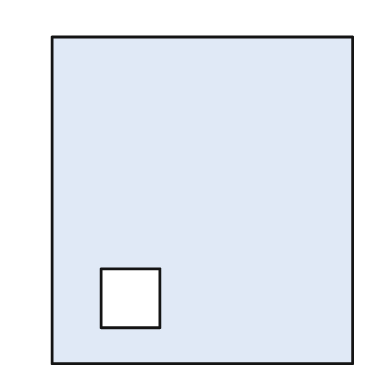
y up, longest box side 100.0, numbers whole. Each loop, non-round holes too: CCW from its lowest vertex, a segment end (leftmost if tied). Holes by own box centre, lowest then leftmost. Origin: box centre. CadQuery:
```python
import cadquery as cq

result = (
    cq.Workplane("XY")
    .moveTo(-46.0, -50.0)
    .lineTo(46.0, -50.0)
    .lineTo(46.0, 50.0)
    .lineTo(-46.0, 50.0)
    .close()
    .moveTo(-31.0, -39.0)
    .lineTo(-13.0, -39.0)
    .lineTo(-13.0, -21.0)
    .lineTo(-31.0, -21.0)
    .close()
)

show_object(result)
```